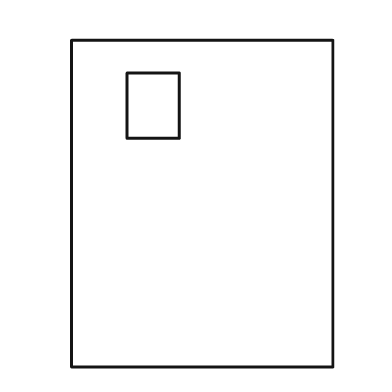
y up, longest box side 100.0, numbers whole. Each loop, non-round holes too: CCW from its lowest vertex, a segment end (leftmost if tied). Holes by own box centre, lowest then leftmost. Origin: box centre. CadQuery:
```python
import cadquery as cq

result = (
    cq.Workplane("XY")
    .moveTo(-40.0, -50.0)
    .lineTo(40.0, -50.0)
    .lineTo(40.0, 50.0)
    .lineTo(-40.0, 50.0)
    .close()
    .moveTo(-23.0, 20.0)
    .lineTo(-7.0, 20.0)
    .lineTo(-7.0, 40.0)
    .lineTo(-23.0, 40.0)
    .close()
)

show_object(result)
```